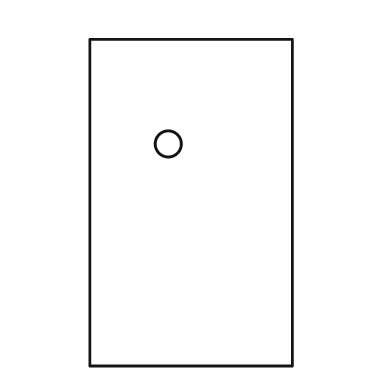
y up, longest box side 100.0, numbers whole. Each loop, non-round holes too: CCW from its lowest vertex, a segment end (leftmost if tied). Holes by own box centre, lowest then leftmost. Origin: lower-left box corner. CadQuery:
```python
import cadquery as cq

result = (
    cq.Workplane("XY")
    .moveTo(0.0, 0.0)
    .lineTo(62.0, 0.0)
    .lineTo(62.0, 100.0)
    .lineTo(0.0, 100.0)
    .close()
    .moveTo(24.0, 68.0)
    .circle(4.0)
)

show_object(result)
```